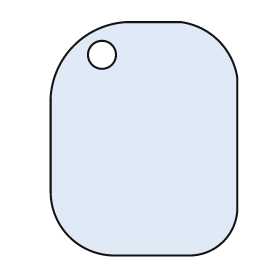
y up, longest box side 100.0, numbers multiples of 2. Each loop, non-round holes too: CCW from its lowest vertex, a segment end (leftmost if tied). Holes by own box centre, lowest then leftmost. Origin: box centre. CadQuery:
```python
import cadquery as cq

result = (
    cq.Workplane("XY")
    .moveTo(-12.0, -50.0)
    .lineTo(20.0, -50.0)
    .threePointArc((34.0, -44.0), (40.0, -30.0))
    .lineTo(40.0, 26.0)
    .threePointArc((32.0, 42.0), (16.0, 50.0))
    .lineTo(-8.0, 50.0)
    .threePointArc((-30.0, 40.0), (-40.0, 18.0))
    .lineTo(-40.0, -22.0)
    .threePointArc((-32.0, -42.0), (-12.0, -50.0))
    .close()
    .moveTo(-18.0, 36.0)
    .circle(6.0)
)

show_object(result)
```